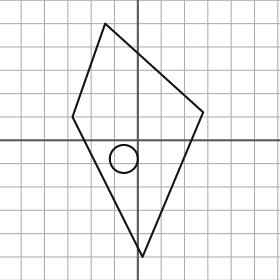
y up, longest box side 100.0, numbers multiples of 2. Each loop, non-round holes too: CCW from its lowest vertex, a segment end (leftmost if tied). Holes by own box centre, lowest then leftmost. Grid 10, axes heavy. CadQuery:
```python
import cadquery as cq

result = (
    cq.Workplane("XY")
    .moveTo(2.0, -50.0)
    .lineTo(28.0, 12.0)
    .lineTo(-14.0, 50.0)
    .lineTo(-28.0, 10.0)
    .close()
    .moveTo(-6.0, -8.0)
    .circle(6.0)
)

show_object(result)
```